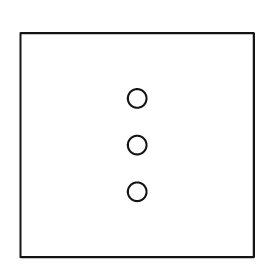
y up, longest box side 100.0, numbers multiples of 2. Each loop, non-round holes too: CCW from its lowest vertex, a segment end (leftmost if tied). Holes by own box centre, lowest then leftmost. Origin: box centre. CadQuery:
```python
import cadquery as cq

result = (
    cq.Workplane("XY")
    .moveTo(-50.0, -48.0)
    .lineTo(50.0, -48.0)
    .lineTo(50.0, 48.0)
    .lineTo(-50.0, 48.0)
    .close()
    .moveTo(0.0, -20.0)
    .circle(4.0)
    .moveTo(0.0, 0.0)
    .circle(4.0)
    .moveTo(0.0, 20.0)
    .circle(4.0)
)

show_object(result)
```